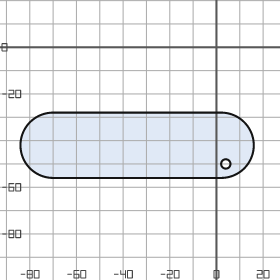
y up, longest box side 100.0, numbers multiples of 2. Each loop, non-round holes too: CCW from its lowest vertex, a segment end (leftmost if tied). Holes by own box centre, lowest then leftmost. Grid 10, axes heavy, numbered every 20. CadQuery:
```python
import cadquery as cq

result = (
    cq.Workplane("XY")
    .moveTo(-70.0, -56.0)
    .lineTo(2.0, -56.0)
    .threePointArc((16.0, -42.0), (2.0, -28.0))
    .lineTo(-70.0, -28.0)
    .threePointArc((-84.0, -42.0), (-70.0, -56.0))
    .close()
    .moveTo(4.0, -50.0)
    .circle(2.0)
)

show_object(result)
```